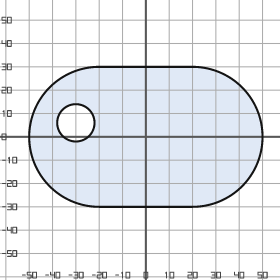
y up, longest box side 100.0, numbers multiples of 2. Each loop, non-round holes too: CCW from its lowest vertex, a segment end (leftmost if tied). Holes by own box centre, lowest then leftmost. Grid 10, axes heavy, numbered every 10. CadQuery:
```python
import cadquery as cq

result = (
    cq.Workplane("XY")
    .moveTo(-20.0, -30.0)
    .lineTo(20.0, -30.0)
    .threePointArc((50.0, 0.0), (20.0, 30.0))
    .lineTo(-20.0, 30.0)
    .threePointArc((-50.0, 0.0), (-20.0, -30.0))
    .close()
    .moveTo(-30.0, 6.0)
    .circle(8.0)
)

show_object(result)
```